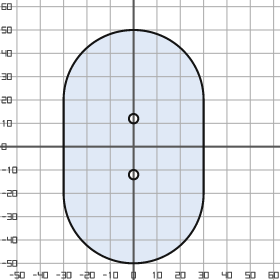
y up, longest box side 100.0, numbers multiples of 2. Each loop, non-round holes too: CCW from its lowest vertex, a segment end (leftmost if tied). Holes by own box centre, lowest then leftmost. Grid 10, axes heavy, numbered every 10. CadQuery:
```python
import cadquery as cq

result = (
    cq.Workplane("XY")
    .moveTo(-30.0, -20.0)
    .threePointArc((0.0, -50.0), (30.0, -20.0))
    .lineTo(30.0, 20.0)
    .threePointArc((0.0, 50.0), (-30.0, 20.0))
    .close()
    .moveTo(0.0, -12.0)
    .circle(2.0)
    .moveTo(0.0, 12.0)
    .circle(2.0)
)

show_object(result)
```